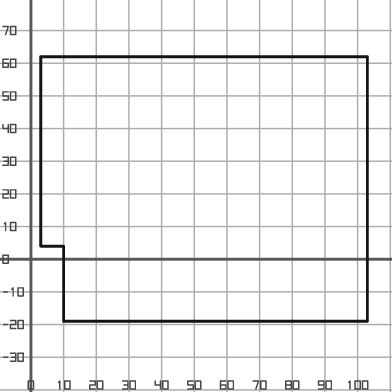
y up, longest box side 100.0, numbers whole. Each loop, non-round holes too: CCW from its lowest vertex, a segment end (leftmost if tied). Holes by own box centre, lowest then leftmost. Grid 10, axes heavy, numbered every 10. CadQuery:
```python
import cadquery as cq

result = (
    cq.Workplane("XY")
    .moveTo(10.0, -19.0)
    .lineTo(103.0, -19.0)
    .lineTo(103.0, 62.0)
    .lineTo(3.0, 62.0)
    .lineTo(3.0, 4.0)
    .lineTo(10.0, 4.0)
    .close()
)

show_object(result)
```